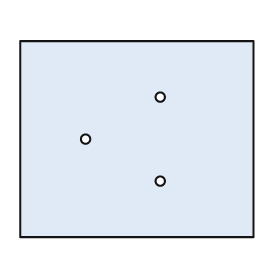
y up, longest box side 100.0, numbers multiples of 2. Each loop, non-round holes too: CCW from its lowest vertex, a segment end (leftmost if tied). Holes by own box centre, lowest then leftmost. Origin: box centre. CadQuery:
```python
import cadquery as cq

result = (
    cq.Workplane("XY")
    .moveTo(-50.0, -42.0)
    .lineTo(50.0, -42.0)
    .lineTo(50.0, 42.0)
    .lineTo(-50.0, 42.0)
    .close()
    .moveTo(10.0, -18.0)
    .circle(2.0)
    .moveTo(-22.0, 0.0)
    .circle(2.0)
    .moveTo(10.0, 18.0)
    .circle(2.0)
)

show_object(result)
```